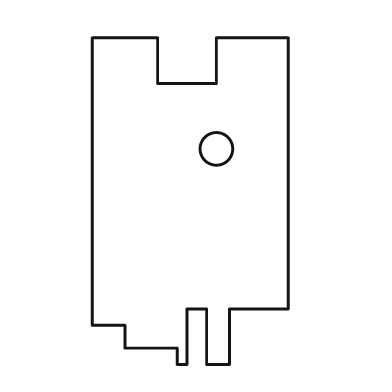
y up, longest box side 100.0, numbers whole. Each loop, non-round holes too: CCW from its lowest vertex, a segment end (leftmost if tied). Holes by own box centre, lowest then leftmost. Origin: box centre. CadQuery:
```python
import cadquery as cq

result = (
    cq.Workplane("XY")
    .moveTo(-4.0, -50.0)
    .lineTo(-1.0, -50.0)
    .lineTo(-1.0, -33.0)
    .lineTo(5.0, -33.0)
    .lineTo(5.0, -50.0)
    .lineTo(12.0, -50.0)
    .lineTo(12.0, -33.0)
    .lineTo(30.0, -33.0)
    .lineTo(30.0, 50.0)
    .lineTo(8.0, 50.0)
    .lineTo(8.0, 36.0)
    .lineTo(-10.0, 36.0)
    .lineTo(-10.0, 50.0)
    .lineTo(-30.0, 50.0)
    .lineTo(-30.0, -38.0)
    .lineTo(-20.0, -38.0)
    .lineTo(-20.0, -45.0)
    .lineTo(-4.0, -45.0)
    .close()
    .moveTo(8.0, 16.0)
    .circle(5.0)
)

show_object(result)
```